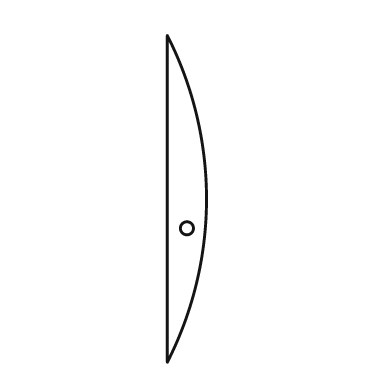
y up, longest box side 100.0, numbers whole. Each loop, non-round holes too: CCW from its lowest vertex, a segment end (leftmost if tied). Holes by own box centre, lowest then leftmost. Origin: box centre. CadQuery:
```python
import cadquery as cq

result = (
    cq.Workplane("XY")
    .moveTo(-6.0, -50.0)
    .threePointArc((6.0, 0.0), (-6.0, 50.0))
    .close()
    .moveTo(0.0, -9.0)
    .circle(2.0)
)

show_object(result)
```